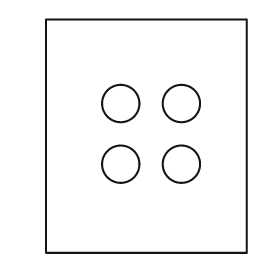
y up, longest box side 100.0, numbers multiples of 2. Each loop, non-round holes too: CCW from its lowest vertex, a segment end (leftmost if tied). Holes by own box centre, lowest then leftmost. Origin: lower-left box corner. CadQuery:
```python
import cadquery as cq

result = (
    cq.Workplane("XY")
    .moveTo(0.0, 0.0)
    .lineTo(86.0, 0.0)
    .lineTo(86.0, 100.0)
    .lineTo(0.0, 100.0)
    .close()
    .moveTo(32.0, 38.0)
    .circle(8.0)
    .moveTo(58.0, 38.0)
    .circle(8.0)
    .moveTo(32.0, 64.0)
    .circle(8.0)
    .moveTo(58.0, 64.0)
    .circle(8.0)
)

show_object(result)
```